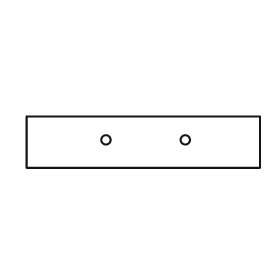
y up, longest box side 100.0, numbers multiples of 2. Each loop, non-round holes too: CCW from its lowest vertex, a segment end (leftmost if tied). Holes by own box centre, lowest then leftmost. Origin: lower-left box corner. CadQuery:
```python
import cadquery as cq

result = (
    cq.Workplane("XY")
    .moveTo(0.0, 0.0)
    .lineTo(100.0, 0.0)
    .lineTo(100.0, 22.0)
    .lineTo(0.0, 22.0)
    .close()
    .moveTo(34.0, 12.0)
    .circle(2.0)
    .moveTo(68.0, 12.0)
    .circle(2.0)
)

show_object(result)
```